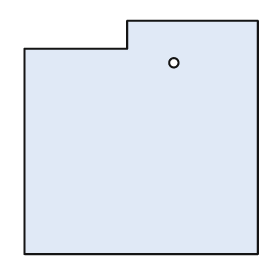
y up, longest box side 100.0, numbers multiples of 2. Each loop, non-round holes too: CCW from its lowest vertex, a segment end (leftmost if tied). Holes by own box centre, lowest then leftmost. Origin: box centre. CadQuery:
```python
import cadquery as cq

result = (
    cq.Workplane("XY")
    .moveTo(-50.0, -50.0)
    .lineTo(50.0, -50.0)
    .lineTo(50.0, 50.0)
    .lineTo(-6.0, 50.0)
    .lineTo(-6.0, 38.0)
    .lineTo(-50.0, 38.0)
    .close()
    .moveTo(14.0, 32.0)
    .circle(2.0)
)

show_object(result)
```